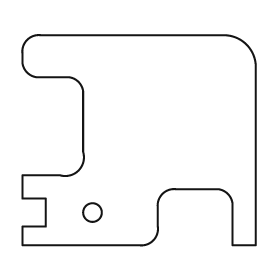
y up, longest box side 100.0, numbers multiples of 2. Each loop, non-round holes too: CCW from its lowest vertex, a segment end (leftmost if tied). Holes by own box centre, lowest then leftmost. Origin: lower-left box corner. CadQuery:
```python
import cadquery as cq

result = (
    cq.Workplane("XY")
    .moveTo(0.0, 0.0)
    .lineTo(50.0, 0.0)
    .threePointArc((56.0, 2.0), (58.0, 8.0))
    .lineTo(58.0, 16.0)
    .threePointArc((60.0, 22.0), (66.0, 24.0))
    .lineTo(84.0, 24.0)
    .threePointArc((88.0, 22.0), (90.0, 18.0))
    .lineTo(90.0, 0.0)
    .lineTo(100.0, 0.0)
    .lineTo(100.0, 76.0)
    .threePointArc((96.0, 86.0), (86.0, 90.0))
    .lineTo(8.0, 90.0)
    .threePointArc((2.0, 88.0), (0.0, 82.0))
    .lineTo(0.0, 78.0)
    .threePointArc((2.0, 74.0), (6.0, 72.0))
    .lineTo(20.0, 72.0)
    .threePointArc((24.0, 70.0), (26.0, 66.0))
    .lineTo(26.0, 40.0)
    .threePointArc((24.0, 32.0), (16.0, 30.0))
    .lineTo(0.0, 30.0)
    .lineTo(0.0, 20.0)
    .lineTo(10.0, 20.0)
    .lineTo(10.0, 8.0)
    .lineTo(0.0, 8.0)
    .close()
    .moveTo(30.0, 14.0)
    .circle(4.0)
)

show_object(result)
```